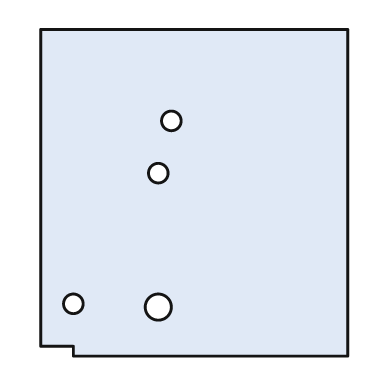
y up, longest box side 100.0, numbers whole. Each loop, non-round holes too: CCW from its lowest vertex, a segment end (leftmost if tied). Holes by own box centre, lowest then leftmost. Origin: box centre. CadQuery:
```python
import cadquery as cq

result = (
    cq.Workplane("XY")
    .moveTo(-37.0, -50.0)
    .lineTo(47.0, -50.0)
    .lineTo(47.0, 50.0)
    .lineTo(-47.0, 50.0)
    .lineTo(-47.0, -47.0)
    .lineTo(-37.0, -47.0)
    .close()
    .moveTo(-11.0, -35.0)
    .circle(4.0)
    .moveTo(-37.0, -34.0)
    .circle(3.0)
    .moveTo(-11.0, 6.0)
    .circle(3.0)
    .moveTo(-7.0, 22.0)
    .circle(3.0)
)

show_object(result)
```